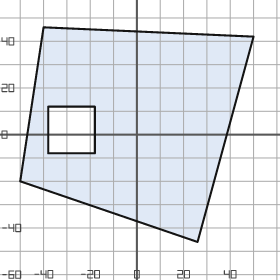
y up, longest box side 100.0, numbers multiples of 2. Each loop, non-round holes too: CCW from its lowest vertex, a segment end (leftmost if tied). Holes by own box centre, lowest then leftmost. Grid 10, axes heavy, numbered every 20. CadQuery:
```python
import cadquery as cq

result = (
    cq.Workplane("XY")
    .moveTo(26.0, -46.0)
    .lineTo(50.0, 42.0)
    .lineTo(-40.0, 46.0)
    .lineTo(-50.0, -20.0)
    .close()
    .moveTo(-38.0, -8.0)
    .lineTo(-18.0, -8.0)
    .lineTo(-18.0, 12.0)
    .lineTo(-38.0, 12.0)
    .close()
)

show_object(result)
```